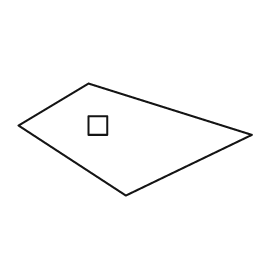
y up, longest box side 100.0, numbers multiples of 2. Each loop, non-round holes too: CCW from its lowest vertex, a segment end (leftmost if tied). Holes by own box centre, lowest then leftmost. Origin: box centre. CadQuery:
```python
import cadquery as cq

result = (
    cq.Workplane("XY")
    .moveTo(-4.0, -24.0)
    .lineTo(50.0, 2.0)
    .lineTo(-20.0, 24.0)
    .lineTo(-50.0, 6.0)
    .close()
    .moveTo(-20.0, 2.0)
    .lineTo(-12.0, 2.0)
    .lineTo(-12.0, 10.0)
    .lineTo(-20.0, 10.0)
    .close()
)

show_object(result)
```